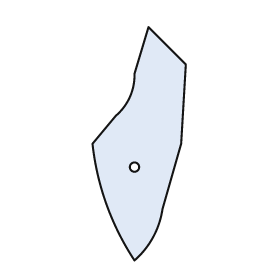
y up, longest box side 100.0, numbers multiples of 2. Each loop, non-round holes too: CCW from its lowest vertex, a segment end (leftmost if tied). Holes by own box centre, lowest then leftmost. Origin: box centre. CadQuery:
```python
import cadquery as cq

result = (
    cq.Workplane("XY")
    .moveTo(-2.0, -50.0)
    .threePointArc((6.0, -40.0), (10.0, -28.0))
    .lineTo(18.0, 0.0)
    .lineTo(20.0, 34.0)
    .lineTo(4.0, 50.0)
    .lineTo(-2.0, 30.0)
    .threePointArc((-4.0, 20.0), (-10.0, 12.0))
    .lineTo(-20.0, 0.0)
    .threePointArc((-14.0, -26.0), (-2.0, -50.0))
    .close()
    .moveTo(-2.0, -10.0)
    .circle(2.0)
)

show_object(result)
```